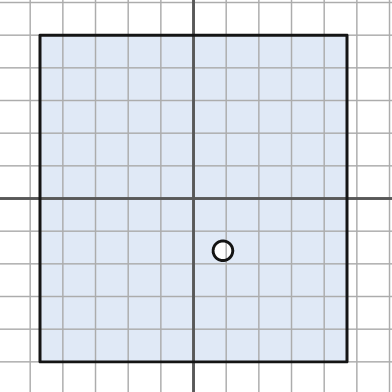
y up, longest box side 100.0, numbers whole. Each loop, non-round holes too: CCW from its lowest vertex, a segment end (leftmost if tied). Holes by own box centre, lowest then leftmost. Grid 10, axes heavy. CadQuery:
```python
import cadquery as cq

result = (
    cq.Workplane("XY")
    .moveTo(-47.0, -50.0)
    .lineTo(47.0, -50.0)
    .lineTo(47.0, 50.0)
    .lineTo(-47.0, 50.0)
    .close()
    .moveTo(9.0, -16.0)
    .circle(3.0)
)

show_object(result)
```